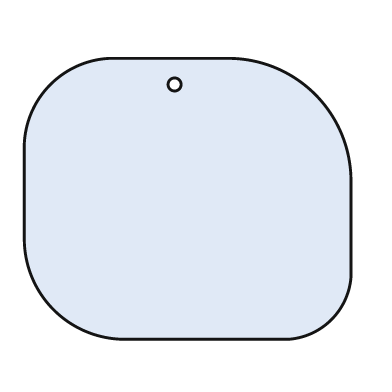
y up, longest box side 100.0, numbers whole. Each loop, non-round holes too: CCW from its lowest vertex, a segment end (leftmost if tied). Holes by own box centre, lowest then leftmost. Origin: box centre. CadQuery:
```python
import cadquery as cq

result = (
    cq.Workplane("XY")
    .moveTo(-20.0, -43.0)
    .lineTo(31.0, -43.0)
    .threePointArc((44.0, -37.0), (50.0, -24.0))
    .lineTo(50.0, 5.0)
    .threePointArc((39.0, 32.0), (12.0, 43.0))
    .lineTo(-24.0, 43.0)
    .threePointArc((-42.0, 35.0), (-50.0, 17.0))
    .lineTo(-50.0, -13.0)
    .threePointArc((-41.0, -34.0), (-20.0, -43.0))
    .close()
    .moveTo(-4.0, 35.0)
    .circle(2.0)
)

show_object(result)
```